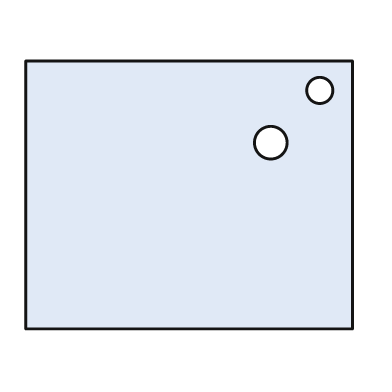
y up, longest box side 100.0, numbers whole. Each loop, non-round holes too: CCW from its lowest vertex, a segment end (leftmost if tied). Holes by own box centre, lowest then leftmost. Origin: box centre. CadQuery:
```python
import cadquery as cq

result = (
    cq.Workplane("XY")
    .moveTo(-50.0, -41.0)
    .lineTo(50.0, -41.0)
    .lineTo(50.0, 41.0)
    .lineTo(-50.0, 41.0)
    .close()
    .moveTo(25.0, 16.0)
    .circle(5.0)
    .moveTo(40.0, 32.0)
    .circle(4.0)
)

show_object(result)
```